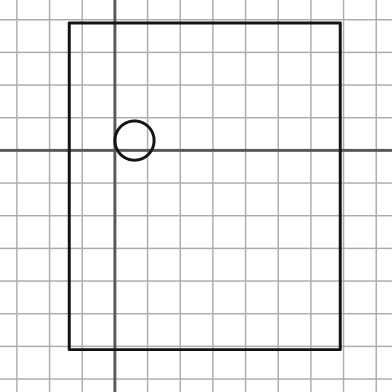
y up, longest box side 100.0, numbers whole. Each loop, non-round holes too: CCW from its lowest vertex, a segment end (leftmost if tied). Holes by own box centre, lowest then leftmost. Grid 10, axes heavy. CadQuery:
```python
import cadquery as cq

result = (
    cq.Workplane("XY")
    .moveTo(-14.0, -61.0)
    .lineTo(69.0, -61.0)
    .lineTo(69.0, 39.0)
    .lineTo(-14.0, 39.0)
    .close()
    .moveTo(6.0, 3.0)
    .circle(6.0)
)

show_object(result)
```